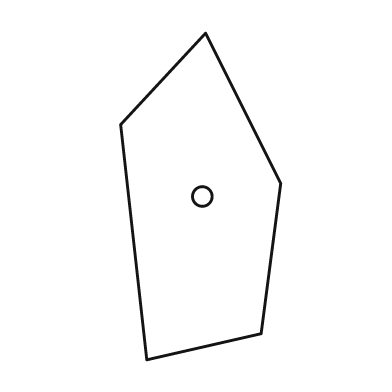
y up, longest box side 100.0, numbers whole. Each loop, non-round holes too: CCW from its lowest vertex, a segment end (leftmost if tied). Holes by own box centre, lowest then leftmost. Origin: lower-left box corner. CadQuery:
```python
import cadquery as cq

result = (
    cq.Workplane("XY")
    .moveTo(8.0, 0.0)
    .lineTo(43.0, 8.0)
    .lineTo(49.0, 54.0)
    .lineTo(26.0, 100.0)
    .lineTo(0.0, 72.0)
    .close()
    .moveTo(25.0, 50.0)
    .circle(3.0)
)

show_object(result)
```